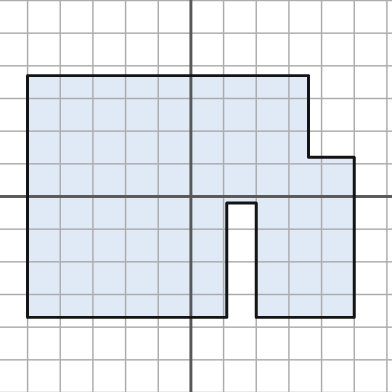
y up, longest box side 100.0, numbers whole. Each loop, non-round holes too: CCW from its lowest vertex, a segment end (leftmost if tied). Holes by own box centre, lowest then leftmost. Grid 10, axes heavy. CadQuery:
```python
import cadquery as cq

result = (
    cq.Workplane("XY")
    .moveTo(-50.0, -37.0)
    .lineTo(11.0, -37.0)
    .lineTo(11.0, -2.0)
    .lineTo(20.0, -2.0)
    .lineTo(20.0, -37.0)
    .lineTo(50.0, -37.0)
    .lineTo(50.0, 12.0)
    .lineTo(36.0, 12.0)
    .lineTo(36.0, 37.0)
    .lineTo(-50.0, 37.0)
    .close()
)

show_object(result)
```